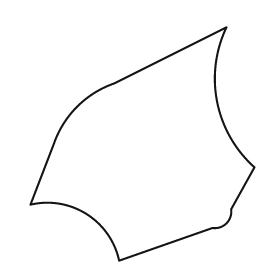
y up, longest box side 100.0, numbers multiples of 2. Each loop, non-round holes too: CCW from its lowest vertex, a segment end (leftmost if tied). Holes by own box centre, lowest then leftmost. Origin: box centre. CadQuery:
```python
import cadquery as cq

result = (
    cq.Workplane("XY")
    .moveTo(-10.0, -50.0)
    .lineTo(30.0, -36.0)
    .threePointArc((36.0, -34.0), (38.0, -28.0))
    .lineTo(48.0, -10.0)
    .threePointArc((32.0, 18.0), (36.0, 50.0))
    .lineTo(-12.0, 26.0)
    .threePointArc((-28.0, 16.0), (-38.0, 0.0))
    .lineTo(-48.0, -26.0)
    .threePointArc((-24.0, -30.0), (-10.0, -50.0))
    .close()
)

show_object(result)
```